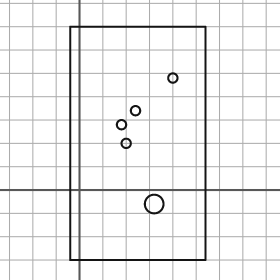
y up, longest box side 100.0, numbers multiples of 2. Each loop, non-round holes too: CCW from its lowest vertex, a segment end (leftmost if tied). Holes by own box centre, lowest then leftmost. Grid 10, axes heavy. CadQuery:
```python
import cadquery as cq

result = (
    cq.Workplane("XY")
    .moveTo(-4.0, -30.0)
    .lineTo(54.0, -30.0)
    .lineTo(54.0, 70.0)
    .lineTo(-4.0, 70.0)
    .close()
    .moveTo(32.0, -6.0)
    .circle(4.0)
    .moveTo(20.0, 20.0)
    .circle(2.0)
    .moveTo(18.0, 28.0)
    .circle(2.0)
    .moveTo(24.0, 34.0)
    .circle(2.0)
    .moveTo(40.0, 48.0)
    .circle(2.0)
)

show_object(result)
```